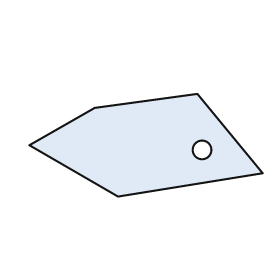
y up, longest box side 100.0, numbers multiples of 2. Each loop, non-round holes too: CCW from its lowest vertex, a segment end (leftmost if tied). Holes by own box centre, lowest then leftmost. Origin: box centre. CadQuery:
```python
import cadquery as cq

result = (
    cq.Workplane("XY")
    .moveTo(-12.0, -22.0)
    .lineTo(50.0, -12.0)
    .lineTo(22.0, 22.0)
    .lineTo(-22.0, 16.0)
    .lineTo(-50.0, 0.0)
    .close()
    .moveTo(24.0, -2.0)
    .circle(4.0)
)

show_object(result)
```